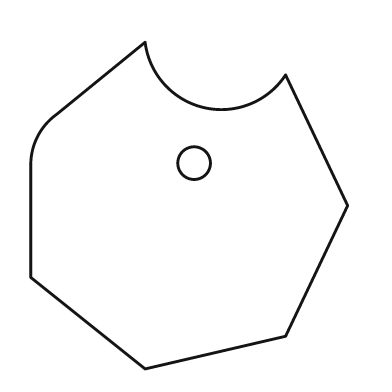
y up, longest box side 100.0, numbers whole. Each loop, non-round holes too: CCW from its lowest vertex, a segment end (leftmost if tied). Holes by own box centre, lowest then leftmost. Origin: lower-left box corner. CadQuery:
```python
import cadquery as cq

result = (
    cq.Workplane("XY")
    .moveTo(35.0, 0.0)
    .lineTo(78.0, 10.0)
    .lineTo(97.0, 50.0)
    .lineTo(78.0, 90.0)
    .threePointArc((53.0, 80.0), (35.0, 100.0))
    .lineTo(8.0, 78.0)
    .threePointArc((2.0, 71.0), (0.0, 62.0))
    .lineTo(0.0, 28.0)
    .close()
    .moveTo(50.0, 63.0)
    .circle(5.0)
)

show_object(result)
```